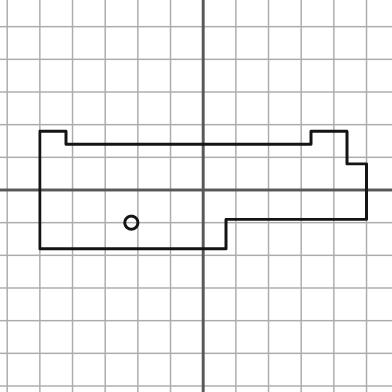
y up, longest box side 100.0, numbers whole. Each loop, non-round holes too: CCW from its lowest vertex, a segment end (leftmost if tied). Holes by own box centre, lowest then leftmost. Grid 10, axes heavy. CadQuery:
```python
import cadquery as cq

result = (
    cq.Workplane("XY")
    .moveTo(-50.0, -18.0)
    .lineTo(7.0, -18.0)
    .lineTo(7.0, -9.0)
    .lineTo(50.0, -9.0)
    .lineTo(50.0, 8.0)
    .lineTo(44.0, 8.0)
    .lineTo(44.0, 18.0)
    .lineTo(33.0, 18.0)
    .lineTo(33.0, 14.0)
    .lineTo(-42.0, 14.0)
    .lineTo(-42.0, 18.0)
    .lineTo(-50.0, 18.0)
    .close()
    .moveTo(-22.0, -10.0)
    .circle(2.0)
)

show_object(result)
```